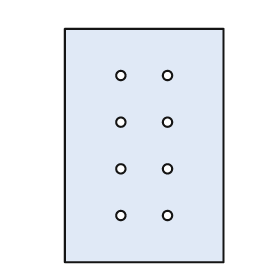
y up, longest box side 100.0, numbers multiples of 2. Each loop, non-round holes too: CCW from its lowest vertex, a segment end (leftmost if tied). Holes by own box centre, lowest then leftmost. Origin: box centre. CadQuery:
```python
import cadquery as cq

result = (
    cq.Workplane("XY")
    .moveTo(-34.0, -50.0)
    .lineTo(34.0, -50.0)
    .lineTo(34.0, 50.0)
    .lineTo(-34.0, 50.0)
    .close()
    .moveTo(-10.0, -30.0)
    .circle(2.0)
    .moveTo(10.0, -30.0)
    .circle(2.0)
    .moveTo(-10.0, -10.0)
    .circle(2.0)
    .moveTo(10.0, -10.0)
    .circle(2.0)
    .moveTo(-10.0, 10.0)
    .circle(2.0)
    .moveTo(10.0, 10.0)
    .circle(2.0)
    .moveTo(-10.0, 30.0)
    .circle(2.0)
    .moveTo(10.0, 30.0)
    .circle(2.0)
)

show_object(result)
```